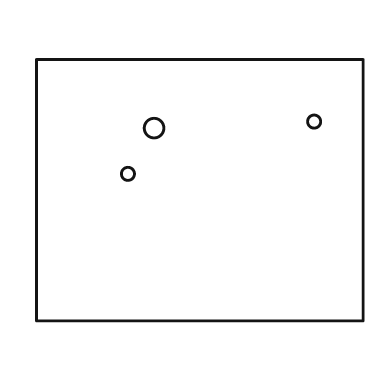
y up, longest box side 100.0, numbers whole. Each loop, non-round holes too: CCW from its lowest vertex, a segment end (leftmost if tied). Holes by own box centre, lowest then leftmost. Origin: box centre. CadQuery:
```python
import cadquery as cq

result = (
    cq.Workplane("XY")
    .moveTo(-50.0, -40.0)
    .lineTo(50.0, -40.0)
    .lineTo(50.0, 40.0)
    .lineTo(-50.0, 40.0)
    .close()
    .moveTo(-22.0, 5.0)
    .circle(2.0)
    .moveTo(-14.0, 19.0)
    .circle(3.0)
    .moveTo(35.0, 21.0)
    .circle(2.0)
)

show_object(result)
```